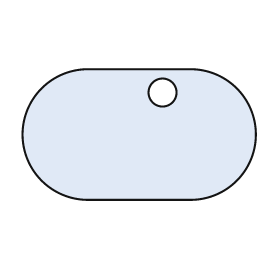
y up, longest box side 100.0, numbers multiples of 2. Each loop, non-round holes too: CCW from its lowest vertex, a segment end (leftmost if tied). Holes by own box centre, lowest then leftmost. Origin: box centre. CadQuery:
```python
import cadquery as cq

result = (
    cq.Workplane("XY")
    .moveTo(-22.0, -28.0)
    .lineTo(22.0, -28.0)
    .threePointArc((50.0, 0.0), (22.0, 28.0))
    .lineTo(-22.0, 28.0)
    .threePointArc((-50.0, 0.0), (-22.0, -28.0))
    .close()
    .moveTo(10.0, 18.0)
    .circle(6.0)
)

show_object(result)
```